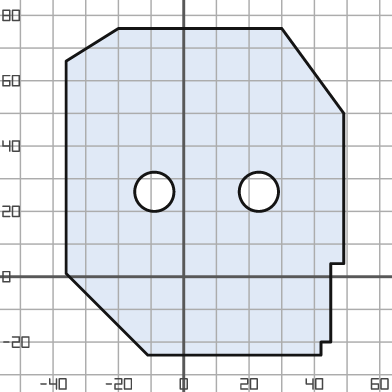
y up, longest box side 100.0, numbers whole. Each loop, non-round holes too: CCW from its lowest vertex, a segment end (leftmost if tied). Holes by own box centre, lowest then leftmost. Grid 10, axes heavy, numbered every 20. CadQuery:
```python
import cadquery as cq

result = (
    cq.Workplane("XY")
    .moveTo(-11.0, -24.0)
    .lineTo(42.0, -24.0)
    .lineTo(42.0, -20.0)
    .lineTo(45.0, -20.0)
    .lineTo(45.0, 4.0)
    .lineTo(49.0, 4.0)
    .lineTo(49.0, 50.0)
    .lineTo(30.0, 76.0)
    .lineTo(-20.0, 76.0)
    .lineTo(-36.0, 66.0)
    .lineTo(-36.0, 1.0)
    .close()
    .moveTo(-9.0, 26.0)
    .circle(6.0)
    .moveTo(23.0, 26.0)
    .circle(6.0)
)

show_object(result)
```